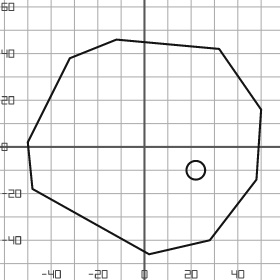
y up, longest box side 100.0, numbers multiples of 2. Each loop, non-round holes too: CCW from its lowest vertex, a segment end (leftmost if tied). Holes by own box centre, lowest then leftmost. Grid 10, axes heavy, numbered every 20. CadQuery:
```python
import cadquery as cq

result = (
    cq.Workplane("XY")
    .moveTo(2.0, -46.0)
    .lineTo(28.0, -40.0)
    .lineTo(48.0, -14.0)
    .lineTo(50.0, 16.0)
    .lineTo(32.0, 42.0)
    .lineTo(-12.0, 46.0)
    .lineTo(-32.0, 38.0)
    .lineTo(-50.0, 2.0)
    .lineTo(-48.0, -18.0)
    .close()
    .moveTo(22.0, -10.0)
    .circle(4.0)
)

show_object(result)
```